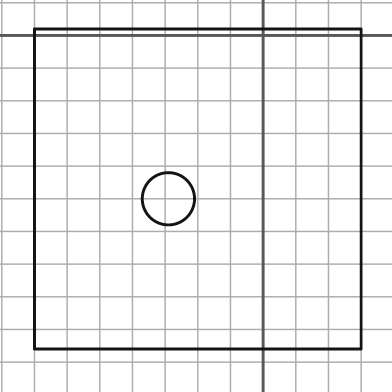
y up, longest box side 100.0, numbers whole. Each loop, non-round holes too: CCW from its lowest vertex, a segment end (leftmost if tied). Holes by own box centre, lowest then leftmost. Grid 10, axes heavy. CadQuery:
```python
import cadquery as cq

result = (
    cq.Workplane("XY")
    .moveTo(-70.0, -96.0)
    .lineTo(30.0, -96.0)
    .lineTo(30.0, 2.0)
    .lineTo(-70.0, 2.0)
    .close()
    .moveTo(-29.0, -50.0)
    .circle(8.0)
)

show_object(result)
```